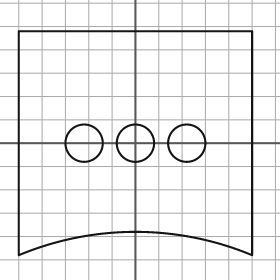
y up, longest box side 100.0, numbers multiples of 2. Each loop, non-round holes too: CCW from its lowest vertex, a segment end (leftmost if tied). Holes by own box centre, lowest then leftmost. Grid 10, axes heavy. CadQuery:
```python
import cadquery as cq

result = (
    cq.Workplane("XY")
    .moveTo(-50.0, -48.0)
    .threePointArc((0.0, -38.0), (50.0, -48.0))
    .lineTo(50.0, 48.0)
    .lineTo(-50.0, 48.0)
    .close()
    .moveTo(-22.0, 0.0)
    .circle(8.0)
    .moveTo(0.0, 0.0)
    .circle(8.0)
    .moveTo(22.0, 0.0)
    .circle(8.0)
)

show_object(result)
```